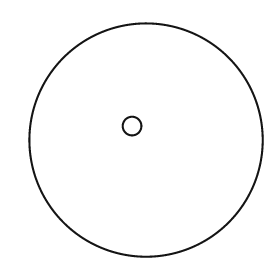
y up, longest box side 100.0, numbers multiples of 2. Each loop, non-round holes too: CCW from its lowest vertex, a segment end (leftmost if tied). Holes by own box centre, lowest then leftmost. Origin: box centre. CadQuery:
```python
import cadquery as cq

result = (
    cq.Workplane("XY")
    .moveTo(0.0, 0.0)
    .circle(50.0)
    .moveTo(-6.0, 6.0)
    .circle(4.0)
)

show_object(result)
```